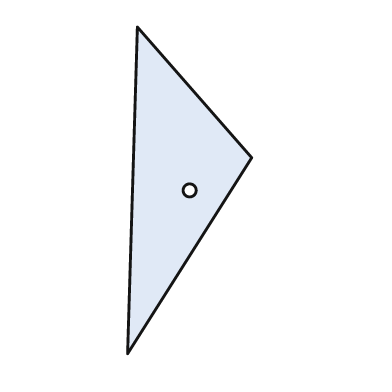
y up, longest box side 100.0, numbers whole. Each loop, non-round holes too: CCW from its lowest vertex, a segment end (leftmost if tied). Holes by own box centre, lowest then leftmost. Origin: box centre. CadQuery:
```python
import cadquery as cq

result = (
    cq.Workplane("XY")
    .moveTo(-19.0, -50.0)
    .lineTo(19.0, 10.0)
    .lineTo(-16.0, 50.0)
    .close()
    .moveTo(0.0, 0.0)
    .circle(2.0)
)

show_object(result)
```